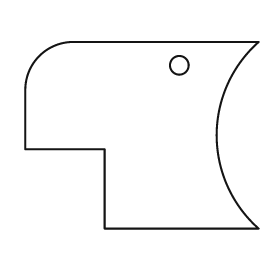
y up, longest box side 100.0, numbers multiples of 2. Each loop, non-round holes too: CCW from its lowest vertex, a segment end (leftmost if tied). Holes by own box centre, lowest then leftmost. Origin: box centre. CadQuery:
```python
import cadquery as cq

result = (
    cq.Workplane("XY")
    .moveTo(-16.0, -40.0)
    .lineTo(50.0, -40.0)
    .threePointArc((32.0, 0.0), (50.0, 40.0))
    .lineTo(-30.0, 40.0)
    .threePointArc((-44.0, 34.0), (-50.0, 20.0))
    .lineTo(-50.0, -6.0)
    .lineTo(-16.0, -6.0)
    .close()
    .moveTo(16.0, 30.0)
    .circle(4.0)
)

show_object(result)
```